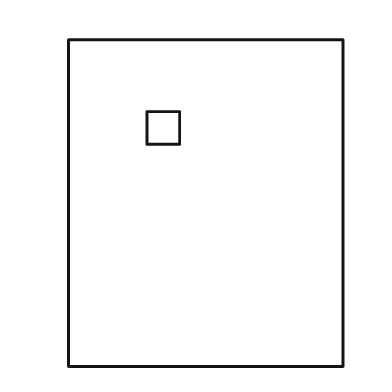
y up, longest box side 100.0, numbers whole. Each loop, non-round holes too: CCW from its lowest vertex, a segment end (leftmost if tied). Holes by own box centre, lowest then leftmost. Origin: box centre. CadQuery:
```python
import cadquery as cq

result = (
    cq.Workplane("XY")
    .moveTo(-42.0, -50.0)
    .lineTo(42.0, -50.0)
    .lineTo(42.0, 50.0)
    .lineTo(-42.0, 50.0)
    .close()
    .moveTo(-18.0, 18.0)
    .lineTo(-8.0, 18.0)
    .lineTo(-8.0, 28.0)
    .lineTo(-18.0, 28.0)
    .close()
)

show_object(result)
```